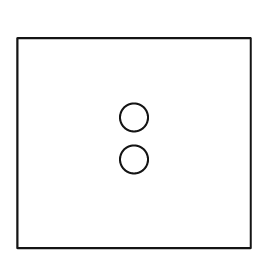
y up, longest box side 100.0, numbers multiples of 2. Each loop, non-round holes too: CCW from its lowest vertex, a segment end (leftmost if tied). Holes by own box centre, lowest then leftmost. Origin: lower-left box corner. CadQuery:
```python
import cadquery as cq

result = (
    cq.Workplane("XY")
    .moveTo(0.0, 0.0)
    .lineTo(100.0, 0.0)
    .lineTo(100.0, 90.0)
    .lineTo(0.0, 90.0)
    .close()
    .moveTo(50.0, 38.0)
    .circle(6.0)
    .moveTo(50.0, 56.0)
    .circle(6.0)
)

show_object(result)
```